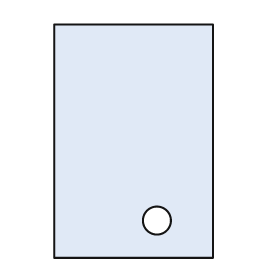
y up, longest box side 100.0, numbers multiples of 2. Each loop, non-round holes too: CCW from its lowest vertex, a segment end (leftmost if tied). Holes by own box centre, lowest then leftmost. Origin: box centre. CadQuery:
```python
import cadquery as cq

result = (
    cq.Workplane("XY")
    .moveTo(-34.0, -50.0)
    .lineTo(34.0, -50.0)
    .lineTo(34.0, 50.0)
    .lineTo(-34.0, 50.0)
    .close()
    .moveTo(10.0, -34.0)
    .circle(6.0)
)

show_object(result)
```